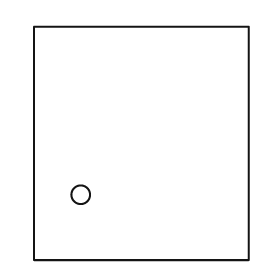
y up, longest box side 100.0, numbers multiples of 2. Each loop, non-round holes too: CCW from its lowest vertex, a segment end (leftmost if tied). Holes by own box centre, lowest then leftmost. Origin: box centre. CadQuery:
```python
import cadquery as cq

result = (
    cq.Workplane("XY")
    .moveTo(-46.0, -50.0)
    .lineTo(46.0, -50.0)
    .lineTo(46.0, 50.0)
    .lineTo(-46.0, 50.0)
    .close()
    .moveTo(-26.0, -22.0)
    .circle(4.0)
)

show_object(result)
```